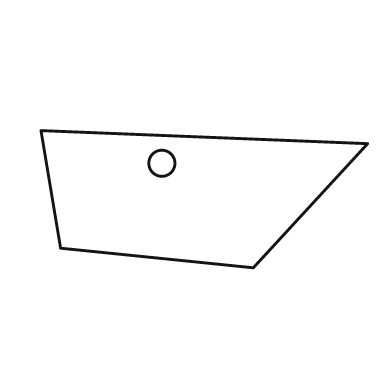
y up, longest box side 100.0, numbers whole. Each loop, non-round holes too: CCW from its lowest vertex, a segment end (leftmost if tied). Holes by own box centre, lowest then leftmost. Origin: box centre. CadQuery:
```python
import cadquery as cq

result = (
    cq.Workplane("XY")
    .moveTo(15.0, -21.0)
    .lineTo(50.0, 17.0)
    .lineTo(-50.0, 21.0)
    .lineTo(-44.0, -15.0)
    .close()
    .moveTo(-13.0, 11.0)
    .circle(4.0)
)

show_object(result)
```